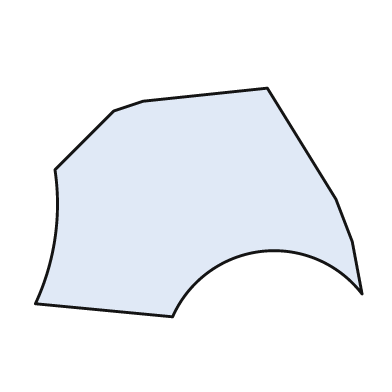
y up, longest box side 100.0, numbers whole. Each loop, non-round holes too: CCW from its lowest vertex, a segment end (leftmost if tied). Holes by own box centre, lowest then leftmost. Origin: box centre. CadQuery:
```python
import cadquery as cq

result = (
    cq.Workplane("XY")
    .moveTo(-8.0, -35.0)
    .threePointArc((19.0, -15.0), (50.0, -28.0))
    .lineTo(47.0, -12.0)
    .lineTo(42.0, 1.0)
    .lineTo(21.0, 35.0)
    .lineTo(-17.0, 31.0)
    .lineTo(-26.0, 28.0)
    .lineTo(-44.0, 10.0)
    .threePointArc((-44.0, -11.0), (-50.0, -31.0))
    .close()
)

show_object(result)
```